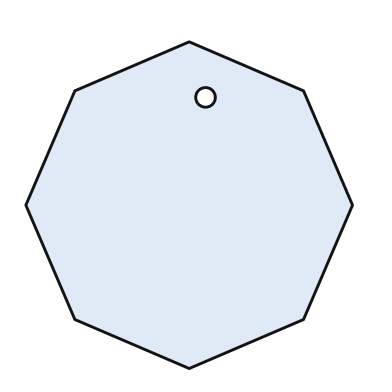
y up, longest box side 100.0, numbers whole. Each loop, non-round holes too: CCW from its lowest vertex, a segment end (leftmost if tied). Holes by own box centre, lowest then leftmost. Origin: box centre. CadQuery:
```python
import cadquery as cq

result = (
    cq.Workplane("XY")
    .moveTo(0.0, -50.0)
    .lineTo(35.0, -35.0)
    .lineTo(50.0, 0.0)
    .lineTo(35.0, 35.0)
    .lineTo(0.0, 50.0)
    .lineTo(-35.0, 35.0)
    .lineTo(-50.0, 0.0)
    .lineTo(-35.0, -35.0)
    .close()
    .moveTo(5.0, 33.0)
    .circle(3.0)
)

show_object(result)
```